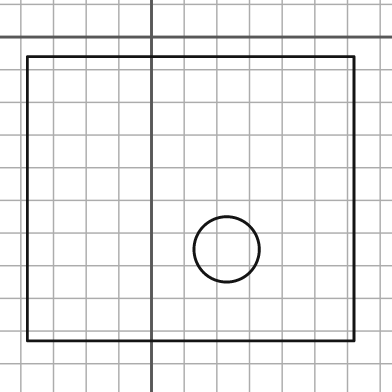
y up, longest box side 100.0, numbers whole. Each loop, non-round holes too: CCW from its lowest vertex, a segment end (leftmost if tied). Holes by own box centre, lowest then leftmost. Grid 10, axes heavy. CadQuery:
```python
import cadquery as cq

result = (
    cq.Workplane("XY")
    .moveTo(-38.0, -93.0)
    .lineTo(62.0, -93.0)
    .lineTo(62.0, -6.0)
    .lineTo(-38.0, -6.0)
    .close()
    .moveTo(23.0, -65.0)
    .circle(10.0)
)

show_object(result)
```